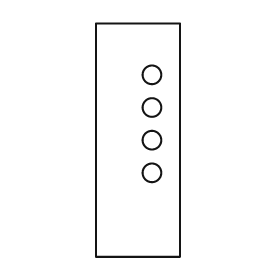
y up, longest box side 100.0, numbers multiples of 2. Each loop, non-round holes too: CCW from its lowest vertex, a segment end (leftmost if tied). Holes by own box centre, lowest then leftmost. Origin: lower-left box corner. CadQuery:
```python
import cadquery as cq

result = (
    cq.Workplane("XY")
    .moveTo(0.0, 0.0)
    .lineTo(36.0, 0.0)
    .lineTo(36.0, 100.0)
    .lineTo(0.0, 100.0)
    .close()
    .moveTo(24.0, 36.0)
    .circle(4.0)
    .moveTo(24.0, 50.0)
    .circle(4.0)
    .moveTo(24.0, 64.0)
    .circle(4.0)
    .moveTo(24.0, 78.0)
    .circle(4.0)
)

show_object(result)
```